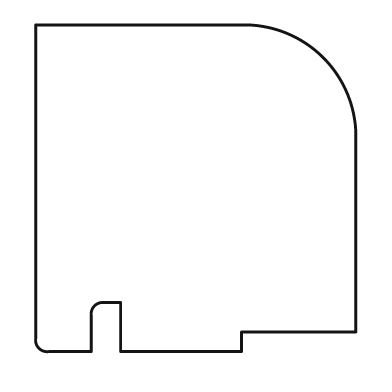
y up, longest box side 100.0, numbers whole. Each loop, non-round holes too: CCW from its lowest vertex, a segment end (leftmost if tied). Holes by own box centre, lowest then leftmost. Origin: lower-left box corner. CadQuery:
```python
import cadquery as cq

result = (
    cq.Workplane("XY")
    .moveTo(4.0, 0.0)
    .lineTo(17.0, 0.0)
    .lineTo(17.0, 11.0)
    .threePointArc((18.0, 14.0), (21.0, 15.0))
    .lineTo(26.0, 15.0)
    .lineTo(26.0, 0.0)
    .lineTo(63.0, 0.0)
    .lineTo(63.0, 6.0)
    .lineTo(98.0, 6.0)
    .lineTo(98.0, 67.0)
    .threePointArc((88.0, 90.0), (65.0, 100.0))
    .lineTo(0.0, 100.0)
    .lineTo(0.0, 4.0)
    .threePointArc((1.0, 1.0), (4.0, 0.0))
    .close()
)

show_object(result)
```